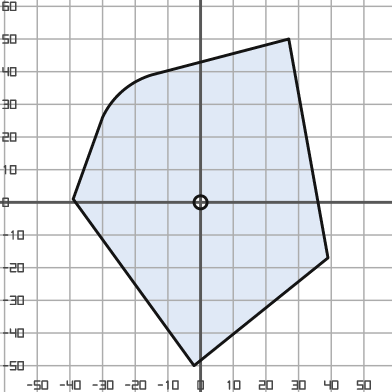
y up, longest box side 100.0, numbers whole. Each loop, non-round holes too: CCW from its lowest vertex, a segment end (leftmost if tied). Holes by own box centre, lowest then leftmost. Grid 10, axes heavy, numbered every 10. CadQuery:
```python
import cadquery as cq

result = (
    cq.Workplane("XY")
    .moveTo(-2.0, -50.0)
    .lineTo(39.0, -17.0)
    .lineTo(27.0, 50.0)
    .lineTo(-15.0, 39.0)
    .threePointArc((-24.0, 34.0), (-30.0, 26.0))
    .lineTo(-39.0, 1.0)
    .close()
    .moveTo(0.0, 0.0)
    .circle(2.0)
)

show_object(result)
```